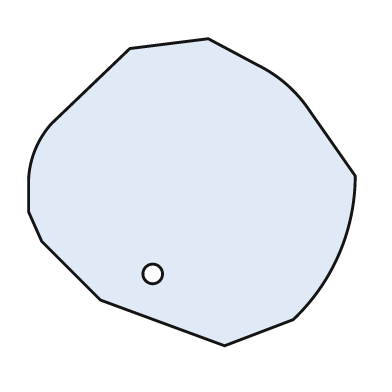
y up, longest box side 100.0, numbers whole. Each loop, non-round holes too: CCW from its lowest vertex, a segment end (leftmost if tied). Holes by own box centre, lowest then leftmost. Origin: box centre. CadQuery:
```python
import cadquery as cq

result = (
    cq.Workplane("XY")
    .moveTo(10.0, -47.0)
    .lineTo(31.0, -39.0)
    .threePointArc((45.0, -19.0), (50.0, 5.0))
    .lineTo(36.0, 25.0)
    .threePointArc((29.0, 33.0), (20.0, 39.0))
    .lineTo(5.0, 47.0)
    .lineTo(-19.0, 44.0)
    .lineTo(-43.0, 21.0)
    .threePointArc((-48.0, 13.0), (-50.0, 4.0))
    .lineTo(-50.0, -6.0)
    .lineTo(-46.0, -15.0)
    .lineTo(-28.0, -33.0)
    .close()
    .moveTo(-12.0, -25.0)
    .circle(3.0)
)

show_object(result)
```